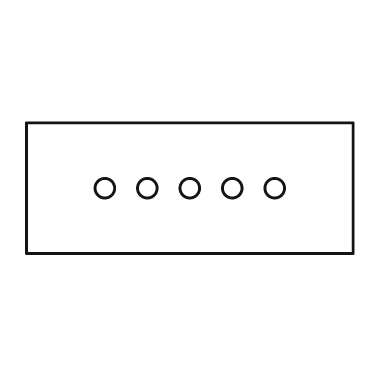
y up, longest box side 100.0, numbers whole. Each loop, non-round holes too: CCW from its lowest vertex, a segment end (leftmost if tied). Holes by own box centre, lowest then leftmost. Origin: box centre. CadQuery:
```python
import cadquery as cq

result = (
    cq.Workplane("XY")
    .moveTo(-50.0, -20.0)
    .lineTo(50.0, -20.0)
    .lineTo(50.0, 20.0)
    .lineTo(-50.0, 20.0)
    .close()
    .moveTo(-26.0, 0.0)
    .circle(3.0)
    .moveTo(-13.0, 0.0)
    .circle(3.0)
    .moveTo(0.0, 0.0)
    .circle(3.0)
    .moveTo(13.0, 0.0)
    .circle(3.0)
    .moveTo(26.0, 0.0)
    .circle(3.0)
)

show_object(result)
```